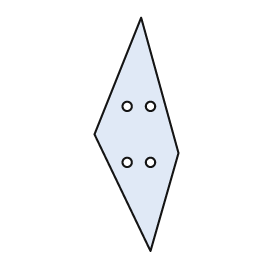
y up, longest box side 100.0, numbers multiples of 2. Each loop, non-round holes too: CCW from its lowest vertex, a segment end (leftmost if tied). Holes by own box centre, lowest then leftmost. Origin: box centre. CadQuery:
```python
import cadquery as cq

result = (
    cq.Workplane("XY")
    .moveTo(6.0, -50.0)
    .lineTo(18.0, -8.0)
    .lineTo(2.0, 50.0)
    .lineTo(-18.0, 0.0)
    .close()
    .moveTo(-4.0, -12.0)
    .circle(2.0)
    .moveTo(6.0, -12.0)
    .circle(2.0)
    .moveTo(-4.0, 12.0)
    .circle(2.0)
    .moveTo(6.0, 12.0)
    .circle(2.0)
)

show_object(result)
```